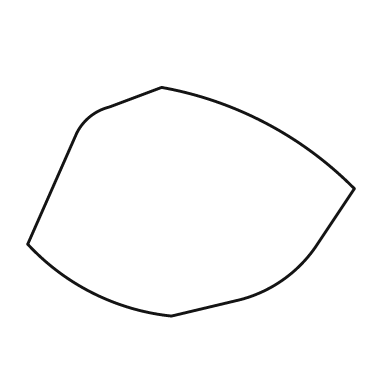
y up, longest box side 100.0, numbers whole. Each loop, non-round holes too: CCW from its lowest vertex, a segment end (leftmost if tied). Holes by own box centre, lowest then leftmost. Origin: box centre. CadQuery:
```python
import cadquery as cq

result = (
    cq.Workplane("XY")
    .moveTo(-6.0, -35.0)
    .lineTo(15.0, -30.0)
    .threePointArc((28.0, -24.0), (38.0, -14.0))
    .lineTo(50.0, 4.0)
    .threePointArc((23.0, 24.0), (-9.0, 35.0))
    .lineTo(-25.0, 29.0)
    .threePointArc((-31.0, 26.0), (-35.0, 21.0))
    .lineTo(-50.0, -13.0)
    .threePointArc((-30.0, -28.0), (-6.0, -35.0))
    .close()
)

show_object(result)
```